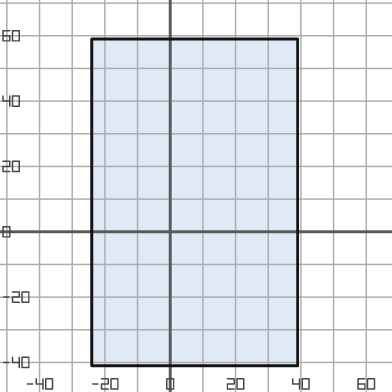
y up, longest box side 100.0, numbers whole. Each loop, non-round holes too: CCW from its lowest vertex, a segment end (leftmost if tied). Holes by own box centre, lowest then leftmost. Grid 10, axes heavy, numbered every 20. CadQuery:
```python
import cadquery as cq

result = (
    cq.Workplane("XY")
    .moveTo(-24.0, -41.0)
    .lineTo(39.0, -41.0)
    .lineTo(39.0, 59.0)
    .lineTo(-24.0, 59.0)
    .close()
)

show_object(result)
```